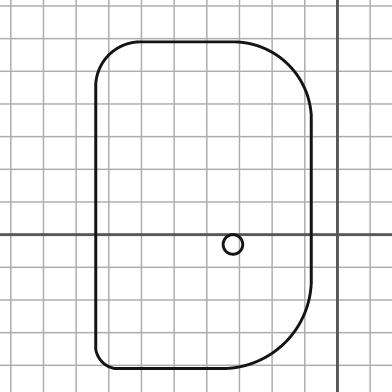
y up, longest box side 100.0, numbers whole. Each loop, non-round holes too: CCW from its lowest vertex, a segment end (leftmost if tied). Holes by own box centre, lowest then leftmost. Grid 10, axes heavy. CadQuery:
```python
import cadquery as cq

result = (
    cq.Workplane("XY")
    .moveTo(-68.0, -41.0)
    .lineTo(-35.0, -41.0)
    .threePointArc((-16.0, -33.0), (-8.0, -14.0))
    .lineTo(-8.0, 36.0)
    .threePointArc((-15.0, 52.0), (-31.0, 59.0))
    .lineTo(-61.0, 59.0)
    .threePointArc((-70.0, 55.0), (-74.0, 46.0))
    .lineTo(-74.0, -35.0)
    .threePointArc((-72.0, -39.0), (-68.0, -41.0))
    .close()
    .moveTo(-32.0, -3.0)
    .circle(3.0)
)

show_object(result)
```